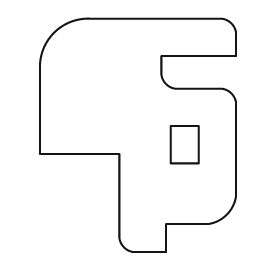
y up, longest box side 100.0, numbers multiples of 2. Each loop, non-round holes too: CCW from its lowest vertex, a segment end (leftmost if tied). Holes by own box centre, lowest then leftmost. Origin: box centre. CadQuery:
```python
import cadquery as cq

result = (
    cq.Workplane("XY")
    .moveTo(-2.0, -50.0)
    .lineTo(12.0, -50.0)
    .lineTo(12.0, -38.0)
    .lineTo(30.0, -38.0)
    .threePointArc((38.0, -34.0), (42.0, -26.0))
    .lineTo(42.0, 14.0)
    .threePointArc((40.0, 18.0), (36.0, 20.0))
    .lineTo(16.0, 20.0)
    .threePointArc((12.0, 22.0), (10.0, 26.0))
    .lineTo(10.0, 34.0)
    .lineTo(42.0, 34.0)
    .lineTo(42.0, 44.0)
    .threePointArc((40.0, 48.0), (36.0, 50.0))
    .lineTo(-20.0, 50.0)
    .threePointArc((-36.0, 44.0), (-42.0, 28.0))
    .lineTo(-42.0, -8.0)
    .lineTo(-8.0, -8.0)
    .lineTo(-8.0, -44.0)
    .threePointArc((-6.0, -48.0), (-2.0, -50.0))
    .close()
    .moveTo(14.0, -12.0)
    .lineTo(26.0, -12.0)
    .lineTo(26.0, 4.0)
    .lineTo(14.0, 4.0)
    .close()
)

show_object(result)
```